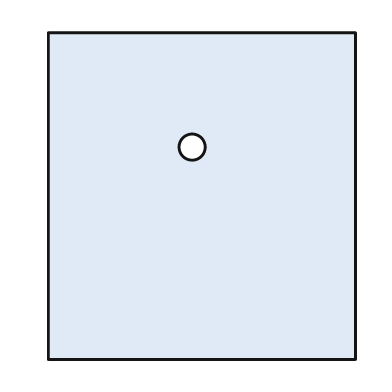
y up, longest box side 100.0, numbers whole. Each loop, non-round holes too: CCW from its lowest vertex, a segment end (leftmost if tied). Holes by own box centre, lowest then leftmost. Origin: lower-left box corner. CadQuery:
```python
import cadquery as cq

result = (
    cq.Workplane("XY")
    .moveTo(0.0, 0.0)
    .lineTo(94.0, 0.0)
    .lineTo(94.0, 100.0)
    .lineTo(0.0, 100.0)
    .close()
    .moveTo(44.0, 65.0)
    .circle(4.0)
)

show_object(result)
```